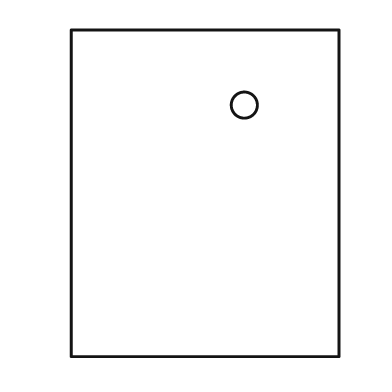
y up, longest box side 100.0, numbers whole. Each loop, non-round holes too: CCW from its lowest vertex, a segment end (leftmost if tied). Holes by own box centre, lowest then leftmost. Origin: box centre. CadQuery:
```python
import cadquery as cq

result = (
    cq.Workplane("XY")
    .moveTo(-41.0, -50.0)
    .lineTo(41.0, -50.0)
    .lineTo(41.0, 50.0)
    .lineTo(-41.0, 50.0)
    .close()
    .moveTo(12.0, 27.0)
    .circle(4.0)
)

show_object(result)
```